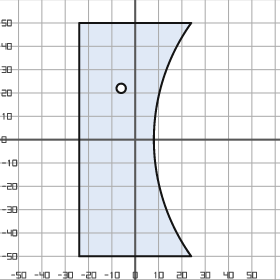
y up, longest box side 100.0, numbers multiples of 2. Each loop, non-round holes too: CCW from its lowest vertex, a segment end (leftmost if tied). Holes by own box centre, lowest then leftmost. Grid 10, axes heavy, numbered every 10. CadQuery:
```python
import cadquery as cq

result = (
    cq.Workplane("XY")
    .moveTo(-24.0, -50.0)
    .lineTo(24.0, -50.0)
    .threePointArc((8.0, 0.0), (24.0, 50.0))
    .lineTo(-24.0, 50.0)
    .close()
    .moveTo(-6.0, 22.0)
    .circle(2.0)
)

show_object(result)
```